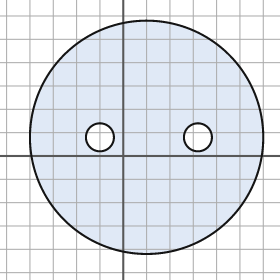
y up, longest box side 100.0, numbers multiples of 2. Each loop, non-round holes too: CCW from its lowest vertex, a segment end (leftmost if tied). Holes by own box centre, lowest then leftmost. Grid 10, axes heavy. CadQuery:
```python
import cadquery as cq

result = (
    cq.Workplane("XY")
    .moveTo(10.0, 8.0)
    .circle(50.0)
    .moveTo(-10.0, 8.0)
    .circle(6.0)
    .moveTo(32.0, 8.0)
    .circle(6.0)
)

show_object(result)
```